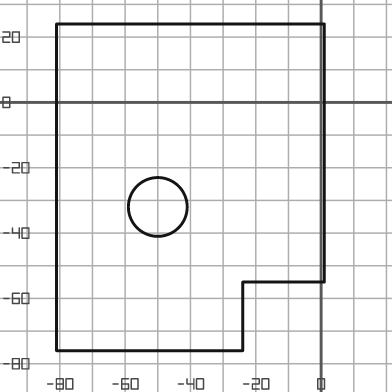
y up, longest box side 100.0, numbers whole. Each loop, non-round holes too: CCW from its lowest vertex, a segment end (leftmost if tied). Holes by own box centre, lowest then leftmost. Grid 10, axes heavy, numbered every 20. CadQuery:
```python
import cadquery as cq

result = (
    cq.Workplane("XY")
    .moveTo(-81.0, -76.0)
    .lineTo(-24.0, -76.0)
    .lineTo(-24.0, -55.0)
    .lineTo(1.0, -55.0)
    .lineTo(1.0, 24.0)
    .lineTo(-81.0, 24.0)
    .close()
    .moveTo(-50.0, -32.0)
    .circle(9.0)
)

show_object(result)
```